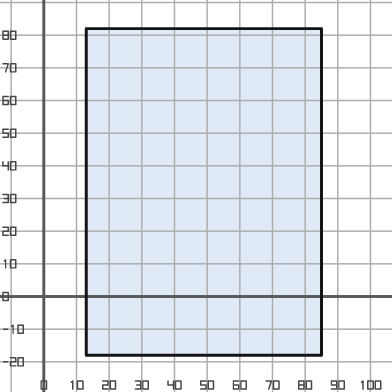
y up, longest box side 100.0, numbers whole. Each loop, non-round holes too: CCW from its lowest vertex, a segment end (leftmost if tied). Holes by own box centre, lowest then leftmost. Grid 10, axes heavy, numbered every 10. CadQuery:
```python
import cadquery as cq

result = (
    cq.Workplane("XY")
    .moveTo(13.0, -18.0)
    .lineTo(85.0, -18.0)
    .lineTo(85.0, 82.0)
    .lineTo(13.0, 82.0)
    .close()
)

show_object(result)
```